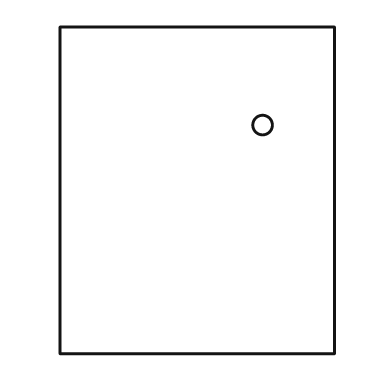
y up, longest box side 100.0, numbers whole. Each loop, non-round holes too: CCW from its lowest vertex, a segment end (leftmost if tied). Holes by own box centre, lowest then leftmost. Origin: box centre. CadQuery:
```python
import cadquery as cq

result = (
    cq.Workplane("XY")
    .moveTo(-42.0, -50.0)
    .lineTo(42.0, -50.0)
    .lineTo(42.0, 50.0)
    .lineTo(-42.0, 50.0)
    .close()
    .moveTo(20.0, 20.0)
    .circle(3.0)
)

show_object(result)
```